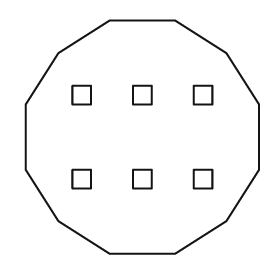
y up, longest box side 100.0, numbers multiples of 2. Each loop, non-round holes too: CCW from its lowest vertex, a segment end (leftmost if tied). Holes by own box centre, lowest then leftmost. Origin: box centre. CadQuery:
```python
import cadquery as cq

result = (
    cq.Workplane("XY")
    .moveTo(-14.0, -50.0)
    .lineTo(14.0, -50.0)
    .lineTo(36.0, -36.0)
    .lineTo(50.0, -14.0)
    .lineTo(50.0, 14.0)
    .lineTo(36.0, 36.0)
    .lineTo(14.0, 50.0)
    .lineTo(-14.0, 50.0)
    .lineTo(-36.0, 36.0)
    .lineTo(-50.0, 14.0)
    .lineTo(-50.0, -14.0)
    .lineTo(-36.0, -36.0)
    .close()
    .moveTo(-30.0, -22.0)
    .lineTo(-22.0, -22.0)
    .lineTo(-22.0, -14.0)
    .lineTo(-30.0, -14.0)
    .close()
    .moveTo(-4.0, -22.0)
    .lineTo(4.0, -22.0)
    .lineTo(4.0, -14.0)
    .lineTo(-4.0, -14.0)
    .close()
    .moveTo(22.0, -22.0)
    .lineTo(30.0, -22.0)
    .lineTo(30.0, -14.0)
    .lineTo(22.0, -14.0)
    .close()
    .moveTo(-30.0, 14.0)
    .lineTo(-22.0, 14.0)
    .lineTo(-22.0, 22.0)
    .lineTo(-30.0, 22.0)
    .close()
    .moveTo(-4.0, 14.0)
    .lineTo(4.0, 14.0)
    .lineTo(4.0, 22.0)
    .lineTo(-4.0, 22.0)
    .close()
    .moveTo(22.0, 14.0)
    .lineTo(30.0, 14.0)
    .lineTo(30.0, 22.0)
    .lineTo(22.0, 22.0)
    .close()
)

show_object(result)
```